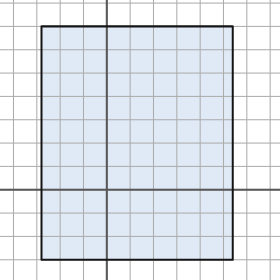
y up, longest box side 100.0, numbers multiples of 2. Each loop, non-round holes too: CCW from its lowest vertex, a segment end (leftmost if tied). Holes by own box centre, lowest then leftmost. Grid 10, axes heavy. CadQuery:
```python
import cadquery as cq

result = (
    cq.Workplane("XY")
    .moveTo(-28.0, -30.0)
    .lineTo(54.0, -30.0)
    .lineTo(54.0, 70.0)
    .lineTo(-28.0, 70.0)
    .close()
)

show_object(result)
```